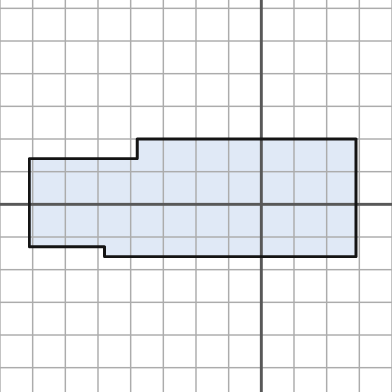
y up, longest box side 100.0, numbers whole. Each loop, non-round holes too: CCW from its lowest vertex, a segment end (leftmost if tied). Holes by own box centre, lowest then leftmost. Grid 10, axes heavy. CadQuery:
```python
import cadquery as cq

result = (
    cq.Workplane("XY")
    .moveTo(-48.0, -16.0)
    .lineTo(29.0, -16.0)
    .lineTo(29.0, 20.0)
    .lineTo(-38.0, 20.0)
    .lineTo(-38.0, 14.0)
    .lineTo(-71.0, 14.0)
    .lineTo(-71.0, -13.0)
    .lineTo(-48.0, -13.0)
    .close()
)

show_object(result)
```